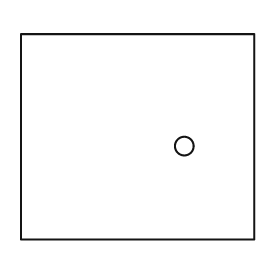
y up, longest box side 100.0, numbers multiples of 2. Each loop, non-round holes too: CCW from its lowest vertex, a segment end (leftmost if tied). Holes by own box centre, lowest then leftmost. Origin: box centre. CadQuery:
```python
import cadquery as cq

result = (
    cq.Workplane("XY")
    .moveTo(-50.0, -44.0)
    .lineTo(50.0, -44.0)
    .lineTo(50.0, 44.0)
    .lineTo(-50.0, 44.0)
    .close()
    .moveTo(20.0, -4.0)
    .circle(4.0)
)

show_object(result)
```